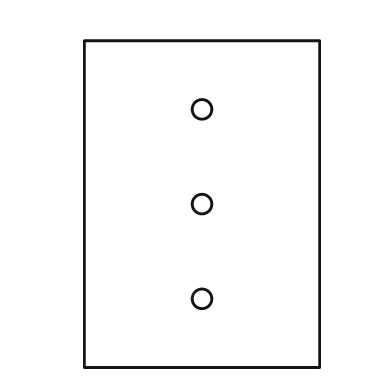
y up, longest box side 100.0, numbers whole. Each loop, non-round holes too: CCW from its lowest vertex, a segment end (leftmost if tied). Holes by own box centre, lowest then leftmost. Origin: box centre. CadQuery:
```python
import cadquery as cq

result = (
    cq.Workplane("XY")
    .moveTo(-36.0, -50.0)
    .lineTo(36.0, -50.0)
    .lineTo(36.0, 50.0)
    .lineTo(-36.0, 50.0)
    .close()
    .moveTo(0.0, -29.0)
    .circle(3.0)
    .moveTo(0.0, 0.0)
    .circle(3.0)
    .moveTo(0.0, 29.0)
    .circle(3.0)
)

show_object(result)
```